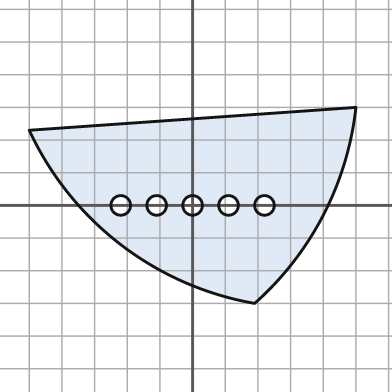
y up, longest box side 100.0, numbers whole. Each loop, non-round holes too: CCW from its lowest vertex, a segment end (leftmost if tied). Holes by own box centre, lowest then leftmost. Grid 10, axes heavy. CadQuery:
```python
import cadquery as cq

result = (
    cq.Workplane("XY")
    .moveTo(19.0, -30.0)
    .threePointArc((40.0, -3.0), (50.0, 30.0))
    .lineTo(-50.0, 23.0)
    .threePointArc((-22.0, -12.0), (19.0, -30.0))
    .close()
    .moveTo(-22.0, 0.0)
    .circle(3.0)
    .moveTo(-11.0, 0.0)
    .circle(3.0)
    .moveTo(0.0, 0.0)
    .circle(3.0)
    .moveTo(11.0, 0.0)
    .circle(3.0)
    .moveTo(22.0, 0.0)
    .circle(3.0)
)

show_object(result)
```